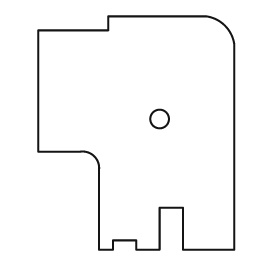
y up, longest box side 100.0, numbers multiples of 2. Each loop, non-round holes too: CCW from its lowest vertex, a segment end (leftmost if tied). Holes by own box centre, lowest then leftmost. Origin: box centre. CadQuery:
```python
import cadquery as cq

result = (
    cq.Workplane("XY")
    .moveTo(-16.0, -50.0)
    .lineTo(-10.0, -50.0)
    .lineTo(-10.0, -46.0)
    .lineTo(0.0, -46.0)
    .lineTo(0.0, -50.0)
    .lineTo(10.0, -50.0)
    .lineTo(10.0, -32.0)
    .lineTo(20.0, -32.0)
    .lineTo(20.0, -50.0)
    .lineTo(42.0, -50.0)
    .lineTo(42.0, 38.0)
    .threePointArc((38.0, 46.0), (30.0, 50.0))
    .lineTo(-12.0, 50.0)
    .lineTo(-12.0, 44.0)
    .lineTo(-42.0, 44.0)
    .lineTo(-42.0, -8.0)
    .lineTo(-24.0, -8.0)
    .threePointArc((-18.0, -10.0), (-16.0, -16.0))
    .close()
    .moveTo(10.0, 6.0)
    .circle(4.0)
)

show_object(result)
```